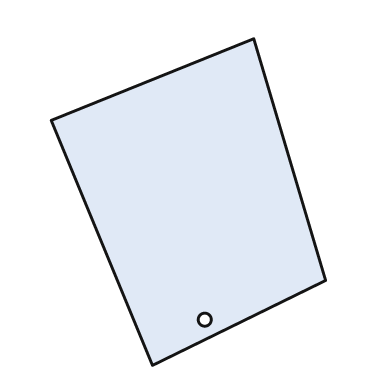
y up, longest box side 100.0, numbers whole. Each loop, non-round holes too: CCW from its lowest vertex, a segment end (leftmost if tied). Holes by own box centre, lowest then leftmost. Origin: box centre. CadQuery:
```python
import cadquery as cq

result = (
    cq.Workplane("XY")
    .moveTo(-11.0, -50.0)
    .lineTo(42.0, -24.0)
    .lineTo(20.0, 50.0)
    .lineTo(-42.0, 25.0)
    .close()
    .moveTo(5.0, -36.0)
    .circle(2.0)
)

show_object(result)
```